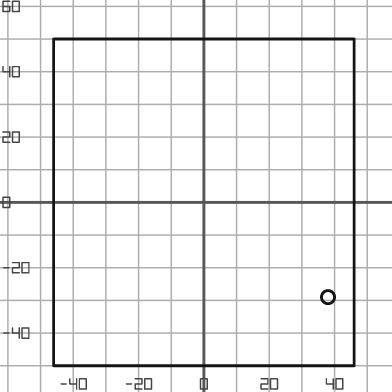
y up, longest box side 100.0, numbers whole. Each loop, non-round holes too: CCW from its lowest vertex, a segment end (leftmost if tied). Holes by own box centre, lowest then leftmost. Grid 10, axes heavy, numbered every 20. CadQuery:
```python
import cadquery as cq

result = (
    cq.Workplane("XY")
    .moveTo(-46.0, -50.0)
    .lineTo(46.0, -50.0)
    .lineTo(46.0, 50.0)
    .lineTo(-46.0, 50.0)
    .close()
    .moveTo(38.0, -29.0)
    .circle(2.0)
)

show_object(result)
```